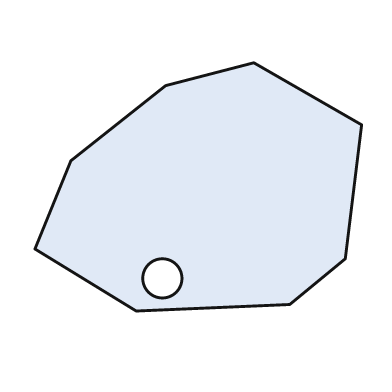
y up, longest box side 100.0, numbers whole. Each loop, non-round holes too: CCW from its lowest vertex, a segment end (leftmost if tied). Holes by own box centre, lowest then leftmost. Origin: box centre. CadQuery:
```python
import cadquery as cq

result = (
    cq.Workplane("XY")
    .moveTo(-19.0, -38.0)
    .lineTo(28.0, -36.0)
    .lineTo(45.0, -22.0)
    .lineTo(50.0, 19.0)
    .lineTo(17.0, 38.0)
    .lineTo(-10.0, 31.0)
    .lineTo(-39.0, 8.0)
    .lineTo(-50.0, -19.0)
    .close()
    .moveTo(-11.0, -28.0)
    .circle(6.0)
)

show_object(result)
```